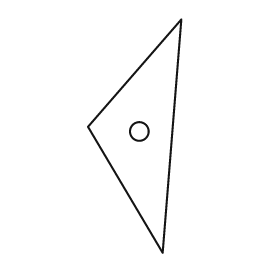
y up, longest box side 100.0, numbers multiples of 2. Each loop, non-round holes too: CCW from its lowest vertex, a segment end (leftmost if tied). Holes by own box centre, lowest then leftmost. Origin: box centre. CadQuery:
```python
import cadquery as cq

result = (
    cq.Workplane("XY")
    .moveTo(12.0, -50.0)
    .lineTo(20.0, 50.0)
    .lineTo(-20.0, 4.0)
    .close()
    .moveTo(2.0, 2.0)
    .circle(4.0)
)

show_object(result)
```